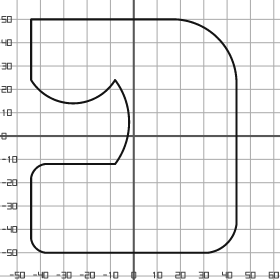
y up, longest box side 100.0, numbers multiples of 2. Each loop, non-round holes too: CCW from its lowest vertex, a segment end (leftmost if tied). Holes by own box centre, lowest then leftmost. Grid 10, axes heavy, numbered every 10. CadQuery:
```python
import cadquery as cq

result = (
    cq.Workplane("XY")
    .moveTo(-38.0, -50.0)
    .lineTo(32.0, -50.0)
    .threePointArc((40.0, -46.0), (44.0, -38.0))
    .lineTo(44.0, 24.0)
    .threePointArc((36.0, 42.0), (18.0, 50.0))
    .lineTo(-44.0, 50.0)
    .lineTo(-44.0, 24.0)
    .threePointArc((-26.0, 14.0), (-8.0, 24.0))
    .threePointArc((-2.0, 6.0), (-8.0, -12.0))
    .lineTo(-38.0, -12.0)
    .threePointArc((-42.0, -14.0), (-44.0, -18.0))
    .lineTo(-44.0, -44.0)
    .threePointArc((-42.0, -48.0), (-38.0, -50.0))
    .close()
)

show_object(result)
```